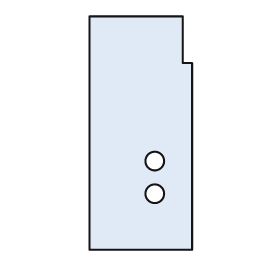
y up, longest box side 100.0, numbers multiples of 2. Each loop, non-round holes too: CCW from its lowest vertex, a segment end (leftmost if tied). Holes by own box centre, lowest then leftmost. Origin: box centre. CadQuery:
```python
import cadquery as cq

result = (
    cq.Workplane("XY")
    .moveTo(-22.0, -50.0)
    .lineTo(22.0, -50.0)
    .lineTo(22.0, 30.0)
    .lineTo(18.0, 30.0)
    .lineTo(18.0, 50.0)
    .lineTo(-22.0, 50.0)
    .close()
    .moveTo(6.0, -26.0)
    .circle(4.0)
    .moveTo(6.0, -12.0)
    .circle(4.0)
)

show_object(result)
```